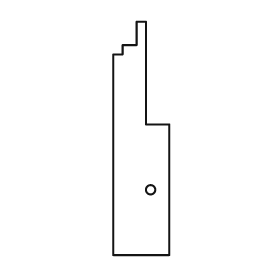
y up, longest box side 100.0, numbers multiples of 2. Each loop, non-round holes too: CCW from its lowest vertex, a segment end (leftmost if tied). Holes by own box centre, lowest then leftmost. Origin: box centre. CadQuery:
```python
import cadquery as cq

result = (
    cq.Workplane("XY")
    .moveTo(-12.0, -50.0)
    .lineTo(12.0, -50.0)
    .lineTo(12.0, 6.0)
    .lineTo(2.0, 6.0)
    .lineTo(2.0, 50.0)
    .lineTo(-2.0, 50.0)
    .lineTo(-2.0, 40.0)
    .lineTo(-8.0, 40.0)
    .lineTo(-8.0, 36.0)
    .lineTo(-12.0, 36.0)
    .close()
    .moveTo(4.0, -22.0)
    .circle(2.0)
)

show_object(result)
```